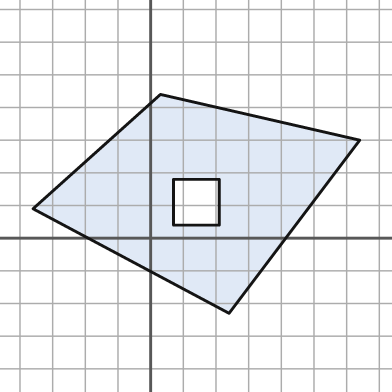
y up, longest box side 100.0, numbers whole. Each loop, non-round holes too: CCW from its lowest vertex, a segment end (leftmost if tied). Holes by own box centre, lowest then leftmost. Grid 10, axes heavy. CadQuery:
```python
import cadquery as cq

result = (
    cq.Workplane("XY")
    .moveTo(24.0, -23.0)
    .lineTo(64.0, 30.0)
    .lineTo(3.0, 44.0)
    .lineTo(-36.0, 9.0)
    .close()
    .moveTo(7.0, 4.0)
    .lineTo(21.0, 4.0)
    .lineTo(21.0, 18.0)
    .lineTo(7.0, 18.0)
    .close()
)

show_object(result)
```